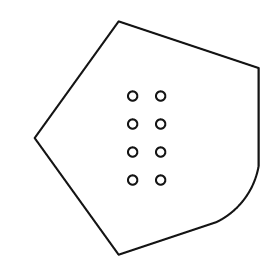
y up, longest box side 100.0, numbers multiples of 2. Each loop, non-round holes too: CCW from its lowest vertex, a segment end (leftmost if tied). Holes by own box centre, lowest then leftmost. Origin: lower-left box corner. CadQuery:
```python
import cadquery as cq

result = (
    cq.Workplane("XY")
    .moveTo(36.0, 0.0)
    .lineTo(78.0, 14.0)
    .threePointArc((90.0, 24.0), (96.0, 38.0))
    .lineTo(96.0, 80.0)
    .lineTo(36.0, 100.0)
    .lineTo(0.0, 50.0)
    .close()
    .moveTo(42.0, 32.0)
    .circle(2.0)
    .moveTo(54.0, 32.0)
    .circle(2.0)
    .moveTo(42.0, 44.0)
    .circle(2.0)
    .moveTo(54.0, 44.0)
    .circle(2.0)
    .moveTo(42.0, 56.0)
    .circle(2.0)
    .moveTo(54.0, 56.0)
    .circle(2.0)
    .moveTo(42.0, 68.0)
    .circle(2.0)
    .moveTo(54.0, 68.0)
    .circle(2.0)
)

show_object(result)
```